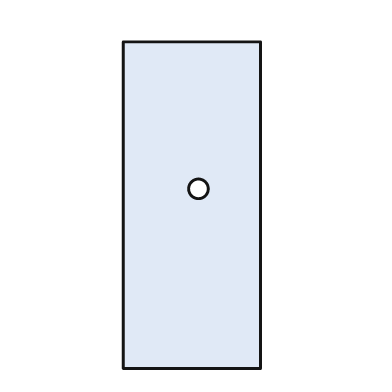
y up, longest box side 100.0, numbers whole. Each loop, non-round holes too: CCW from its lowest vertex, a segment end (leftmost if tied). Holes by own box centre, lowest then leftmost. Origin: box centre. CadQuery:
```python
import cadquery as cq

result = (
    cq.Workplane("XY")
    .moveTo(-21.0, -50.0)
    .lineTo(21.0, -50.0)
    .lineTo(21.0, 50.0)
    .lineTo(-21.0, 50.0)
    .close()
    .moveTo(2.0, 5.0)
    .circle(3.0)
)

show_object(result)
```